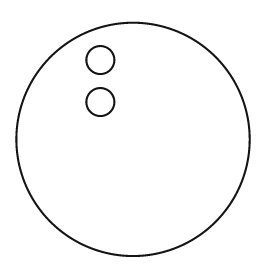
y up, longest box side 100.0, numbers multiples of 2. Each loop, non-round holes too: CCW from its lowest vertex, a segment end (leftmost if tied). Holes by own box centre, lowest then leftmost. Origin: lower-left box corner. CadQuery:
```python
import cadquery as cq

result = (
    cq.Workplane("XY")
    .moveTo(50.0, 50.0)
    .circle(50.0)
    .moveTo(36.0, 66.0)
    .circle(6.0)
    .moveTo(36.0, 84.0)
    .circle(6.0)
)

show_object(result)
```